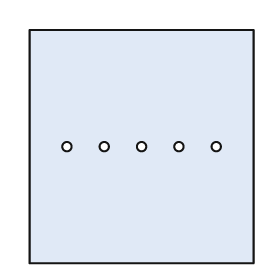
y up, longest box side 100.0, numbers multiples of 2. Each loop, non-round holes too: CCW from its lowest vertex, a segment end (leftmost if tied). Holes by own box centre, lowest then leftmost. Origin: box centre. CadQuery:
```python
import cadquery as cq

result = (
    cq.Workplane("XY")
    .moveTo(-48.0, -50.0)
    .lineTo(48.0, -50.0)
    .lineTo(48.0, 50.0)
    .lineTo(-48.0, 50.0)
    .close()
    .moveTo(-32.0, 0.0)
    .circle(2.0)
    .moveTo(-16.0, 0.0)
    .circle(2.0)
    .moveTo(0.0, 0.0)
    .circle(2.0)
    .moveTo(16.0, 0.0)
    .circle(2.0)
    .moveTo(32.0, 0.0)
    .circle(2.0)
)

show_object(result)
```